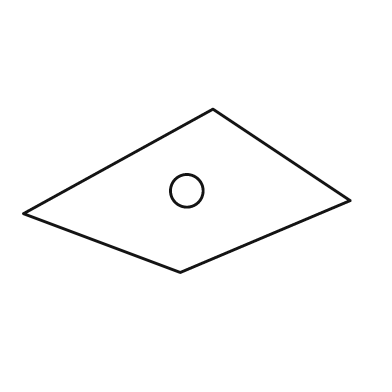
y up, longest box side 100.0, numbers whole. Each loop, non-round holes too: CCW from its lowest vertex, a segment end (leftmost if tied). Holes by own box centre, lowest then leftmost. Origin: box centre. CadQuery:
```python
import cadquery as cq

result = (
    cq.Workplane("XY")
    .moveTo(-2.0, -25.0)
    .lineTo(50.0, -3.0)
    .lineTo(8.0, 25.0)
    .lineTo(-50.0, -7.0)
    .close()
    .moveTo(0.0, 0.0)
    .circle(5.0)
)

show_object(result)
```